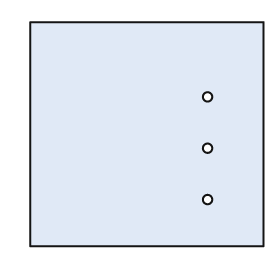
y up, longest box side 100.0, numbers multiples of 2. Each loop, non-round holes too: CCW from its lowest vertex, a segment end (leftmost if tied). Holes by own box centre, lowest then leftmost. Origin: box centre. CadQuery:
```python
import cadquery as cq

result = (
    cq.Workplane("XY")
    .moveTo(-50.0, -48.0)
    .lineTo(50.0, -48.0)
    .lineTo(50.0, 48.0)
    .lineTo(-50.0, 48.0)
    .close()
    .moveTo(26.0, -28.0)
    .circle(2.0)
    .moveTo(26.0, -6.0)
    .circle(2.0)
    .moveTo(26.0, 16.0)
    .circle(2.0)
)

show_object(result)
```